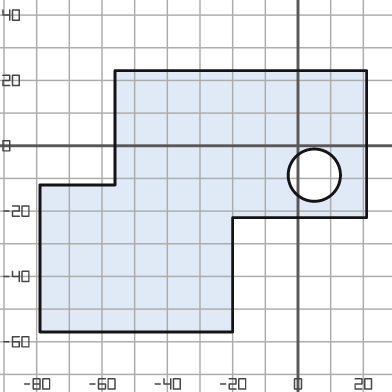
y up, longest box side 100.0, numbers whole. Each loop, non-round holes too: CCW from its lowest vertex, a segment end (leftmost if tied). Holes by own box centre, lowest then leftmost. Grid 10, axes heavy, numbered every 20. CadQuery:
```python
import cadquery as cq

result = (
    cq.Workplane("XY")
    .moveTo(-79.0, -57.0)
    .lineTo(-20.0, -57.0)
    .lineTo(-20.0, -22.0)
    .lineTo(21.0, -22.0)
    .lineTo(21.0, 23.0)
    .lineTo(-56.0, 23.0)
    .lineTo(-56.0, -12.0)
    .lineTo(-79.0, -12.0)
    .close()
    .moveTo(5.0, -9.0)
    .circle(8.0)
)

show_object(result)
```